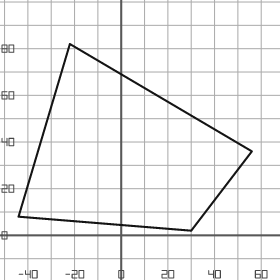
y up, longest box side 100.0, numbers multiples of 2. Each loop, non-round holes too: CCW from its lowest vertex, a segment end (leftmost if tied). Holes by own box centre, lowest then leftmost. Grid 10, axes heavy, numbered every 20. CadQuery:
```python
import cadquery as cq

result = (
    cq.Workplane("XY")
    .moveTo(30.0, 2.0)
    .lineTo(56.0, 36.0)
    .lineTo(-22.0, 82.0)
    .lineTo(-44.0, 8.0)
    .close()
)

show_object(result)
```